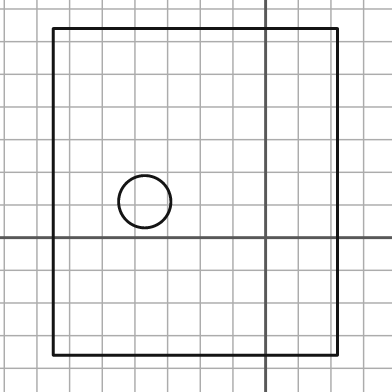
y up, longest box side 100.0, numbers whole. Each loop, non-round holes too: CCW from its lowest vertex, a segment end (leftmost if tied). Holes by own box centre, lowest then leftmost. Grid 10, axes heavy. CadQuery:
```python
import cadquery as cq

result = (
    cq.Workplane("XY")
    .moveTo(-65.0, -36.0)
    .lineTo(22.0, -36.0)
    .lineTo(22.0, 64.0)
    .lineTo(-65.0, 64.0)
    .close()
    .moveTo(-37.0, 11.0)
    .circle(8.0)
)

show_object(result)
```